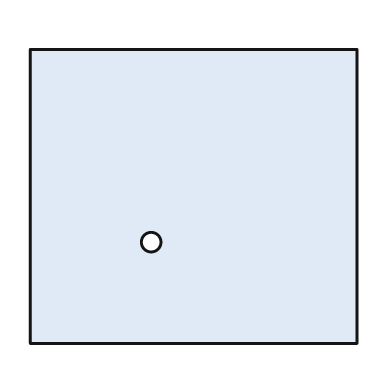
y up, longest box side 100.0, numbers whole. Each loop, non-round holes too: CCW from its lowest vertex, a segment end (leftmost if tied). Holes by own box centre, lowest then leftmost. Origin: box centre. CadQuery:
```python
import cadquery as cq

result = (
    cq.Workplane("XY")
    .moveTo(-50.0, -45.0)
    .lineTo(50.0, -45.0)
    .lineTo(50.0, 45.0)
    .lineTo(-50.0, 45.0)
    .close()
    .moveTo(-13.0, -14.0)
    .circle(3.0)
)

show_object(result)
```